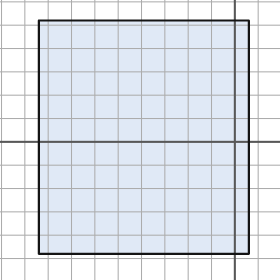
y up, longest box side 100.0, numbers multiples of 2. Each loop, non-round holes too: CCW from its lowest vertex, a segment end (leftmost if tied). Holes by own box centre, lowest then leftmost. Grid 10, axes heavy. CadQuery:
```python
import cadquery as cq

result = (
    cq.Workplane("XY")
    .moveTo(-84.0, -48.0)
    .lineTo(6.0, -48.0)
    .lineTo(6.0, 52.0)
    .lineTo(-84.0, 52.0)
    .close()
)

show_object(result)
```